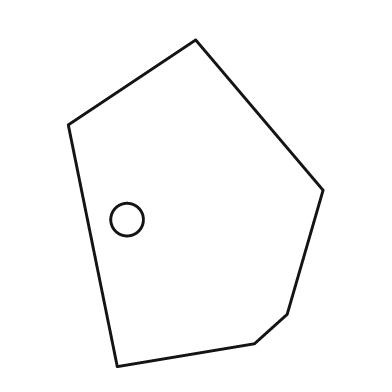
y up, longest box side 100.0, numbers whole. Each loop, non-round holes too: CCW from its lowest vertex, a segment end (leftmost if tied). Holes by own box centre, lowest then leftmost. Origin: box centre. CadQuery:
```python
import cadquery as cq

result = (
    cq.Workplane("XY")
    .moveTo(-24.0, -50.0)
    .lineTo(18.0, -43.0)
    .lineTo(28.0, -34.0)
    .lineTo(39.0, 4.0)
    .lineTo(0.0, 50.0)
    .lineTo(-39.0, 24.0)
    .close()
    .moveTo(-21.0, -5.0)
    .circle(5.0)
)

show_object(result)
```